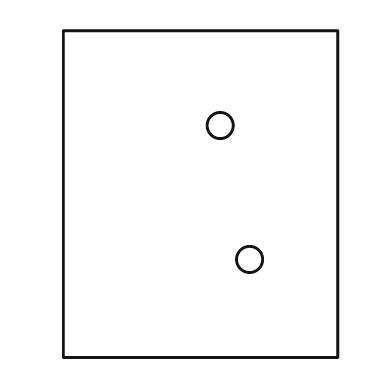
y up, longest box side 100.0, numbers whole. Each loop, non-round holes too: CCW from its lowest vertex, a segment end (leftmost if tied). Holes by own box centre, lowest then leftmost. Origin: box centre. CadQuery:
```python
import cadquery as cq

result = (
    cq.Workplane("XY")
    .moveTo(-42.0, -50.0)
    .lineTo(42.0, -50.0)
    .lineTo(42.0, 50.0)
    .lineTo(-42.0, 50.0)
    .close()
    .moveTo(15.0, -20.0)
    .circle(4.0)
    .moveTo(6.0, 21.0)
    .circle(4.0)
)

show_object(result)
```